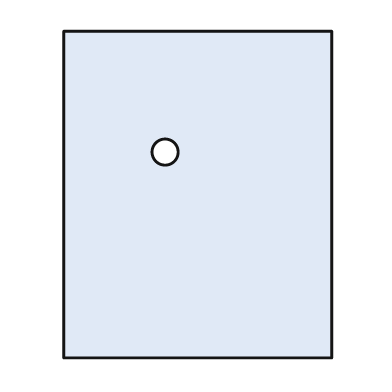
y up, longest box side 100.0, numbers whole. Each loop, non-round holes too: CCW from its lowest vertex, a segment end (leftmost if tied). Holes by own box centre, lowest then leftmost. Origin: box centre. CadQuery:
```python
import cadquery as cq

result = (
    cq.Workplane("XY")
    .moveTo(-41.0, -50.0)
    .lineTo(41.0, -50.0)
    .lineTo(41.0, 50.0)
    .lineTo(-41.0, 50.0)
    .close()
    .moveTo(-10.0, 13.0)
    .circle(4.0)
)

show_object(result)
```